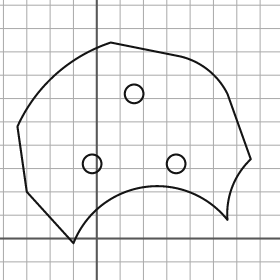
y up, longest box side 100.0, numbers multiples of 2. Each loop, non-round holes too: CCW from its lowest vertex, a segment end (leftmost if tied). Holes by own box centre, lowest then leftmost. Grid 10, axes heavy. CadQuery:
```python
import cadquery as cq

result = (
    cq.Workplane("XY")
    .moveTo(-10.0, -2.0)
    .threePointArc((20.0, 22.0), (56.0, 8.0))
    .threePointArc((58.0, 22.0), (66.0, 34.0))
    .lineTo(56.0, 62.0)
    .threePointArc((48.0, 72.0), (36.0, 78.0))
    .lineTo(6.0, 84.0)
    .threePointArc((-18.0, 70.0), (-34.0, 48.0))
    .lineTo(-30.0, 20.0)
    .close()
    .moveTo(-2.0, 32.0)
    .circle(4.0)
    .moveTo(34.0, 32.0)
    .circle(4.0)
    .moveTo(16.0, 62.0)
    .circle(4.0)
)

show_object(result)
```